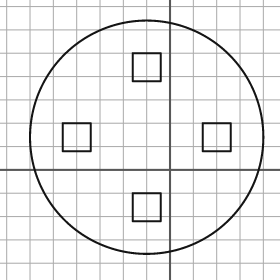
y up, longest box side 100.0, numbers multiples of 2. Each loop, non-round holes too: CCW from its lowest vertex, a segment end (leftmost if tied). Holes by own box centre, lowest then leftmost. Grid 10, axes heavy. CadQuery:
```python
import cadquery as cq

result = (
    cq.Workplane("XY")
    .moveTo(-10.0, 14.0)
    .circle(50.0)
    .moveTo(-16.0, -22.0)
    .lineTo(-4.0, -22.0)
    .lineTo(-4.0, -10.0)
    .lineTo(-16.0, -10.0)
    .close()
    .moveTo(-46.0, 8.0)
    .lineTo(-34.0, 8.0)
    .lineTo(-34.0, 20.0)
    .lineTo(-46.0, 20.0)
    .close()
    .moveTo(14.0, 8.0)
    .lineTo(26.0, 8.0)
    .lineTo(26.0, 20.0)
    .lineTo(14.0, 20.0)
    .close()
    .moveTo(-16.0, 38.0)
    .lineTo(-4.0, 38.0)
    .lineTo(-4.0, 50.0)
    .lineTo(-16.0, 50.0)
    .close()
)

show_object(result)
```